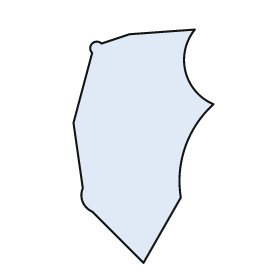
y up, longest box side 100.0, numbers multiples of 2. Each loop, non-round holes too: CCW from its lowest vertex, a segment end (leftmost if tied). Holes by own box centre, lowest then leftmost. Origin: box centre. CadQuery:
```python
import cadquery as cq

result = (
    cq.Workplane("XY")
    .moveTo(0.0, -50.0)
    .lineTo(16.0, -22.0)
    .threePointArc((18.0, 0.0), (30.0, 18.0))
    .threePointArc((18.0, 32.0), (22.0, 50.0))
    .lineTo(-6.0, 48.0)
    .lineTo(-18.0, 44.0)
    .threePointArc((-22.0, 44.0), (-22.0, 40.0))
    .lineTo(-30.0, 10.0)
    .lineTo(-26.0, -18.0)
    .threePointArc((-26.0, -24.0), (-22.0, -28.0))
    .close()
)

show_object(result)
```